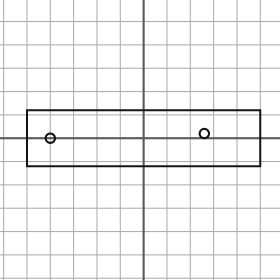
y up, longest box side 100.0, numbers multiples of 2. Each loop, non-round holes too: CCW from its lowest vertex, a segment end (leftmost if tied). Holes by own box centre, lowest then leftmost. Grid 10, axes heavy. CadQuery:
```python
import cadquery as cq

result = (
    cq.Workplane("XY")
    .moveTo(-50.0, -12.0)
    .lineTo(50.0, -12.0)
    .lineTo(50.0, 12.0)
    .lineTo(-50.0, 12.0)
    .close()
    .moveTo(-40.0, 0.0)
    .circle(2.0)
    .moveTo(26.0, 2.0)
    .circle(2.0)
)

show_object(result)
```